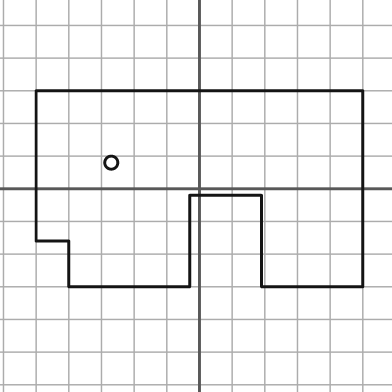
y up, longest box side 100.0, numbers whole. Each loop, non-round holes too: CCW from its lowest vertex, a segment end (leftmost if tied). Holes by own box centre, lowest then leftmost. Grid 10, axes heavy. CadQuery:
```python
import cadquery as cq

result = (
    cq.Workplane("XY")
    .moveTo(-40.0, -30.0)
    .lineTo(-3.0, -30.0)
    .lineTo(-3.0, -2.0)
    .lineTo(19.0, -2.0)
    .lineTo(19.0, -30.0)
    .lineTo(50.0, -30.0)
    .lineTo(50.0, 30.0)
    .lineTo(-50.0, 30.0)
    .lineTo(-50.0, -16.0)
    .lineTo(-40.0, -16.0)
    .close()
    .moveTo(-27.0, 8.0)
    .circle(2.0)
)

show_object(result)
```